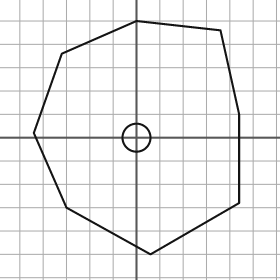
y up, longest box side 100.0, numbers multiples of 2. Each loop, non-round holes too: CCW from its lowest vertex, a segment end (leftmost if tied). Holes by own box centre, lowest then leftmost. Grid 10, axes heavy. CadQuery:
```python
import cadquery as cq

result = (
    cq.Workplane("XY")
    .moveTo(6.0, -50.0)
    .lineTo(44.0, -28.0)
    .lineTo(44.0, 10.0)
    .lineTo(36.0, 46.0)
    .lineTo(0.0, 50.0)
    .lineTo(-32.0, 36.0)
    .lineTo(-44.0, 2.0)
    .lineTo(-30.0, -30.0)
    .close()
    .moveTo(0.0, 0.0)
    .circle(6.0)
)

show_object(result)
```